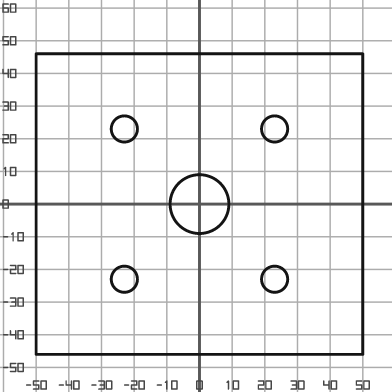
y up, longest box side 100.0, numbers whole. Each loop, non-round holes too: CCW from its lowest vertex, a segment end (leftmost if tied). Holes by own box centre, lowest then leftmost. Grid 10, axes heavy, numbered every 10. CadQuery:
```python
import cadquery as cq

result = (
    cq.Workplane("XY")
    .moveTo(-50.0, -46.0)
    .lineTo(50.0, -46.0)
    .lineTo(50.0, 46.0)
    .lineTo(-50.0, 46.0)
    .close()
    .moveTo(-23.0, -23.0)
    .circle(4.0)
    .moveTo(23.0, -23.0)
    .circle(4.0)
    .moveTo(0.0, 0.0)
    .circle(9.0)
    .moveTo(-23.0, 23.0)
    .circle(4.0)
    .moveTo(23.0, 23.0)
    .circle(4.0)
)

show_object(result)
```